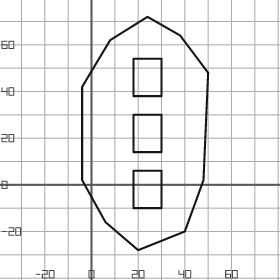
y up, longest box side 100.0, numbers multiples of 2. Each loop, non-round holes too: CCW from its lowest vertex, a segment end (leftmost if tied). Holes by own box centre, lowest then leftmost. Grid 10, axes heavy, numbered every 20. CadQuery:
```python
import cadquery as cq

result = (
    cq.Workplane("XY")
    .moveTo(20.0, -28.0)
    .lineTo(40.0, -20.0)
    .lineTo(48.0, 2.0)
    .lineTo(50.0, 48.0)
    .lineTo(38.0, 64.0)
    .lineTo(24.0, 72.0)
    .lineTo(8.0, 62.0)
    .lineTo(-4.0, 42.0)
    .lineTo(-4.0, 2.0)
    .lineTo(6.0, -16.0)
    .close()
    .moveTo(18.0, -10.0)
    .lineTo(30.0, -10.0)
    .lineTo(30.0, 6.0)
    .lineTo(18.0, 6.0)
    .close()
    .moveTo(18.0, 14.0)
    .lineTo(30.0, 14.0)
    .lineTo(30.0, 30.0)
    .lineTo(18.0, 30.0)
    .close()
    .moveTo(18.0, 38.0)
    .lineTo(30.0, 38.0)
    .lineTo(30.0, 54.0)
    .lineTo(18.0, 54.0)
    .close()
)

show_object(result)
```